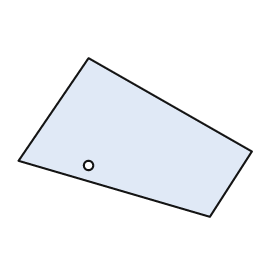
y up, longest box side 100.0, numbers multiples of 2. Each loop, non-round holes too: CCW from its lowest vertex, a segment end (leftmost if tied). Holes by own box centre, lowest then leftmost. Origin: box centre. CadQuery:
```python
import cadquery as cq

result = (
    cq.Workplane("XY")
    .moveTo(32.0, -34.0)
    .lineTo(50.0, -6.0)
    .lineTo(-20.0, 34.0)
    .lineTo(-50.0, -10.0)
    .close()
    .moveTo(-20.0, -12.0)
    .circle(2.0)
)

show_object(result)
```